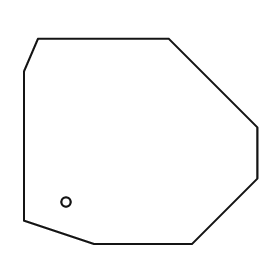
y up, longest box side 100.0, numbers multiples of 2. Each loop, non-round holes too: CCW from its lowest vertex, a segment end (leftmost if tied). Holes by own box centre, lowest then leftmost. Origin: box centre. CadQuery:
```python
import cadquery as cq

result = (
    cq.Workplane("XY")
    .moveTo(-20.0, -44.0)
    .lineTo(22.0, -44.0)
    .lineTo(50.0, -16.0)
    .lineTo(50.0, 6.0)
    .lineTo(12.0, 44.0)
    .lineTo(-44.0, 44.0)
    .lineTo(-50.0, 30.0)
    .lineTo(-50.0, -34.0)
    .close()
    .moveTo(-32.0, -26.0)
    .circle(2.0)
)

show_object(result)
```